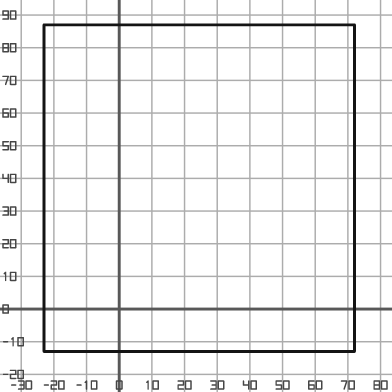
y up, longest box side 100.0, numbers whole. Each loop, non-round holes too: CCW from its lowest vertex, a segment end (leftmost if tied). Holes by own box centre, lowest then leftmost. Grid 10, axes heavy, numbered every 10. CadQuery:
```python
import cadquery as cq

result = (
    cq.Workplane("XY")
    .moveTo(-23.0, -13.0)
    .lineTo(72.0, -13.0)
    .lineTo(72.0, 87.0)
    .lineTo(-23.0, 87.0)
    .close()
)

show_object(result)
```